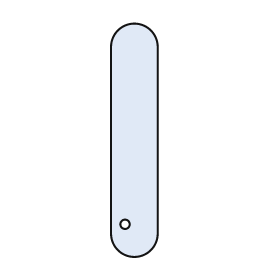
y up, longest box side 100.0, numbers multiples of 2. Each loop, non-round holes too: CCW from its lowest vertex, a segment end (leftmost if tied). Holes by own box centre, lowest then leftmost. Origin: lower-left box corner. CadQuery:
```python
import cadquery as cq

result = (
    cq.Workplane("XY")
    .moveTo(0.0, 10.0)
    .threePointArc((10.0, 0.0), (20.0, 10.0))
    .lineTo(20.0, 90.0)
    .threePointArc((10.0, 100.0), (0.0, 90.0))
    .close()
    .moveTo(6.0, 14.0)
    .circle(2.0)
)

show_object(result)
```